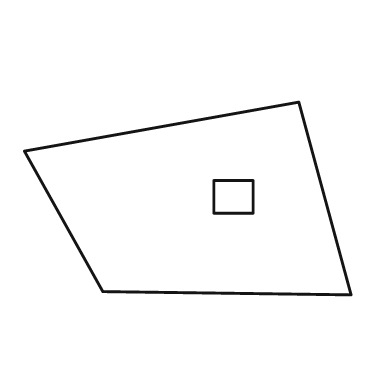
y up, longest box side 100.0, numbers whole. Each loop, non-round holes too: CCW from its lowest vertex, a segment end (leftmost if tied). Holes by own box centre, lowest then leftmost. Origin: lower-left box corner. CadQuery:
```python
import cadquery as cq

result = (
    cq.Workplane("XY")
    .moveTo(100.0, 0.0)
    .lineTo(84.0, 59.0)
    .lineTo(0.0, 44.0)
    .lineTo(24.0, 1.0)
    .close()
    .moveTo(58.0, 25.0)
    .lineTo(70.0, 25.0)
    .lineTo(70.0, 35.0)
    .lineTo(58.0, 35.0)
    .close()
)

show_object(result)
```